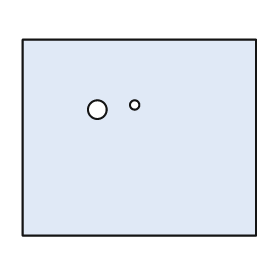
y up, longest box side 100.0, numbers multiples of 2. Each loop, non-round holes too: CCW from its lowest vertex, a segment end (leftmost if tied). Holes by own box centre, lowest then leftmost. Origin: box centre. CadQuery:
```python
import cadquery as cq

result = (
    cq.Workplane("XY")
    .moveTo(-50.0, -42.0)
    .lineTo(50.0, -42.0)
    .lineTo(50.0, 42.0)
    .lineTo(-50.0, 42.0)
    .close()
    .moveTo(-18.0, 12.0)
    .circle(4.0)
    .moveTo(-2.0, 14.0)
    .circle(2.0)
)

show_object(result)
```